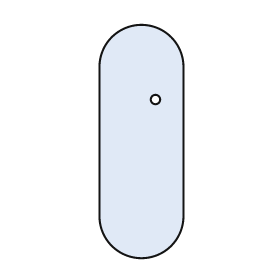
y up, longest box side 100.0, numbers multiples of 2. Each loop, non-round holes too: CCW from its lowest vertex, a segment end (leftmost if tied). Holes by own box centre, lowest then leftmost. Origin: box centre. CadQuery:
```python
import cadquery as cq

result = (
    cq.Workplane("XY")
    .moveTo(-18.0, -32.0)
    .threePointArc((0.0, -50.0), (18.0, -32.0))
    .lineTo(18.0, 32.0)
    .threePointArc((0.0, 50.0), (-18.0, 32.0))
    .close()
    .moveTo(6.0, 18.0)
    .circle(2.0)
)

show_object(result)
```